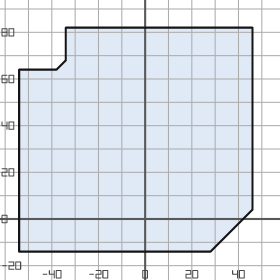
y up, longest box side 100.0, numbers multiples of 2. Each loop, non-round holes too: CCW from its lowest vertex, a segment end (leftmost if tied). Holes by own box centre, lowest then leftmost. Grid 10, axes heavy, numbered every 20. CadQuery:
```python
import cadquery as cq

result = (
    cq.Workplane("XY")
    .moveTo(-54.0, -14.0)
    .lineTo(28.0, -14.0)
    .lineTo(46.0, 4.0)
    .lineTo(46.0, 82.0)
    .lineTo(-34.0, 82.0)
    .lineTo(-34.0, 68.0)
    .lineTo(-38.0, 64.0)
    .lineTo(-54.0, 64.0)
    .close()
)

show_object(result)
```